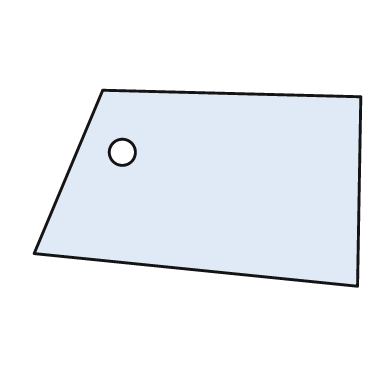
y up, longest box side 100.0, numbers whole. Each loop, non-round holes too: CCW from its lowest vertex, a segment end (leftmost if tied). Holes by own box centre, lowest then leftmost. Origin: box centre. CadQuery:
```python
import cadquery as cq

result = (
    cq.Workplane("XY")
    .moveTo(49.0, -30.0)
    .lineTo(50.0, 28.0)
    .lineTo(-29.0, 30.0)
    .lineTo(-50.0, -20.0)
    .close()
    .moveTo(-23.0, 11.0)
    .circle(4.0)
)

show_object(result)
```